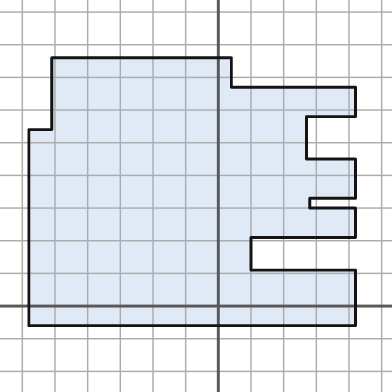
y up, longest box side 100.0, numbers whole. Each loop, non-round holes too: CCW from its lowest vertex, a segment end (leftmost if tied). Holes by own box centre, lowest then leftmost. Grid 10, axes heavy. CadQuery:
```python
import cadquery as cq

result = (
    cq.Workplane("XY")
    .moveTo(-58.0, -6.0)
    .lineTo(42.0, -6.0)
    .lineTo(42.0, 11.0)
    .lineTo(10.0, 11.0)
    .lineTo(10.0, 21.0)
    .lineTo(42.0, 21.0)
    .lineTo(42.0, 30.0)
    .lineTo(28.0, 30.0)
    .lineTo(28.0, 33.0)
    .lineTo(42.0, 33.0)
    .lineTo(42.0, 45.0)
    .lineTo(27.0, 45.0)
    .lineTo(27.0, 58.0)
    .lineTo(42.0, 58.0)
    .lineTo(42.0, 67.0)
    .lineTo(4.0, 67.0)
    .lineTo(4.0, 76.0)
    .lineTo(-51.0, 76.0)
    .lineTo(-51.0, 54.0)
    .lineTo(-58.0, 54.0)
    .close()
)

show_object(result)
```